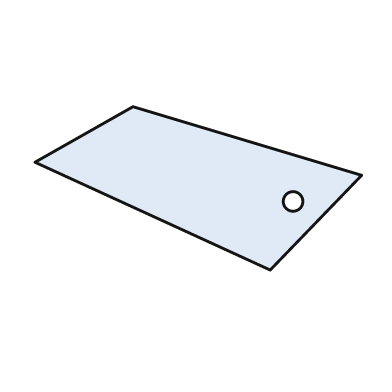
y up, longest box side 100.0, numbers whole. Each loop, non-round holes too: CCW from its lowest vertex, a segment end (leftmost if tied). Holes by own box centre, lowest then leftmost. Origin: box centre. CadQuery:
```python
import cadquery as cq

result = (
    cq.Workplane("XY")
    .moveTo(22.0, -25.0)
    .lineTo(50.0, 4.0)
    .lineTo(-20.0, 25.0)
    .lineTo(-50.0, 8.0)
    .close()
    .moveTo(29.0, -4.0)
    .circle(3.0)
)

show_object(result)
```